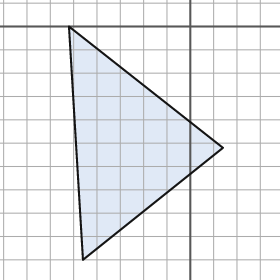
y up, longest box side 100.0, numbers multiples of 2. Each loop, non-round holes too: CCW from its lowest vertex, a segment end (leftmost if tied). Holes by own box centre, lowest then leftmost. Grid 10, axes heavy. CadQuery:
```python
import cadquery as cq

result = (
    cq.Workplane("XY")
    .moveTo(-46.0, -100.0)
    .lineTo(14.0, -52.0)
    .lineTo(-52.0, 0.0)
    .close()
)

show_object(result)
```